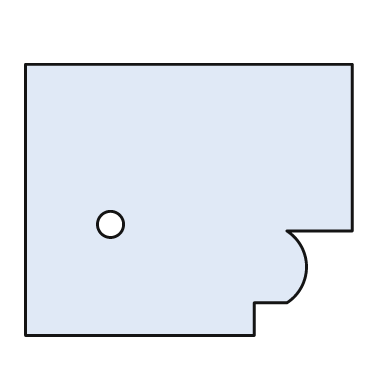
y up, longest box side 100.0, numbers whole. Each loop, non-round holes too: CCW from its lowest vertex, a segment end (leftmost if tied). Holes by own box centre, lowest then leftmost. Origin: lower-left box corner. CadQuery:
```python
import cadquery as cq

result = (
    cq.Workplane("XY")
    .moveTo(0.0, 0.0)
    .lineTo(70.0, 0.0)
    .lineTo(70.0, 10.0)
    .lineTo(80.0, 10.0)
    .threePointArc((86.0, 21.0), (80.0, 32.0))
    .lineTo(100.0, 32.0)
    .lineTo(100.0, 83.0)
    .lineTo(0.0, 83.0)
    .close()
    .moveTo(26.0, 34.0)
    .circle(4.0)
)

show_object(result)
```